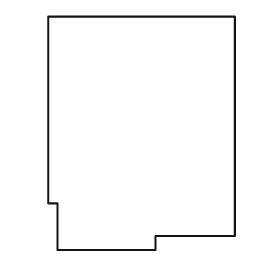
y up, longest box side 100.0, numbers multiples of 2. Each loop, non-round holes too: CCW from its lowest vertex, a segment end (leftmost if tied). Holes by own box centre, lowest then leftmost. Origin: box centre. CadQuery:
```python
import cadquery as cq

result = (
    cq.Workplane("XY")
    .moveTo(-36.0, -50.0)
    .lineTo(6.0, -50.0)
    .lineTo(6.0, -44.0)
    .lineTo(40.0, -44.0)
    .lineTo(40.0, 50.0)
    .lineTo(-40.0, 50.0)
    .lineTo(-40.0, -30.0)
    .lineTo(-36.0, -30.0)
    .close()
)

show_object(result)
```